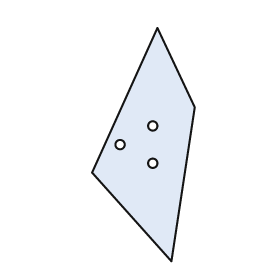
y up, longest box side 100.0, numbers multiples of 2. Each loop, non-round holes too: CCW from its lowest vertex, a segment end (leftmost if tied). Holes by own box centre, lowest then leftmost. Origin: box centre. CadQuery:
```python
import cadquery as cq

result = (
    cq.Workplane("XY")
    .moveTo(12.0, -50.0)
    .lineTo(22.0, 16.0)
    .lineTo(6.0, 50.0)
    .lineTo(-22.0, -12.0)
    .close()
    .moveTo(4.0, -8.0)
    .circle(2.0)
    .moveTo(-10.0, 0.0)
    .circle(2.0)
    .moveTo(4.0, 8.0)
    .circle(2.0)
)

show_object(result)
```